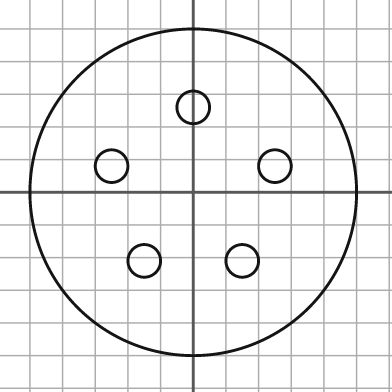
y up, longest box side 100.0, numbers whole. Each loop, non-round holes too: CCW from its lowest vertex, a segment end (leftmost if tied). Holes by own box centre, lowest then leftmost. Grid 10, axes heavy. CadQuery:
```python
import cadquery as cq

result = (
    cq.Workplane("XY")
    .moveTo(0.0, 0.0)
    .circle(50.0)
    .moveTo(-15.0, -21.0)
    .circle(5.0)
    .moveTo(15.0, -21.0)
    .circle(5.0)
    .moveTo(-25.0, 8.0)
    .circle(5.0)
    .moveTo(25.0, 8.0)
    .circle(5.0)
    .moveTo(0.0, 26.0)
    .circle(5.0)
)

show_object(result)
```